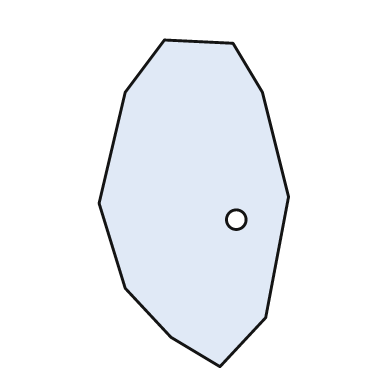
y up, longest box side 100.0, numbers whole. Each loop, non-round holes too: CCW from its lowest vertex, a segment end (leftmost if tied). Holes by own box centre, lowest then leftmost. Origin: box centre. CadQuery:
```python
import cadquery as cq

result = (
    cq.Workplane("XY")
    .moveTo(8.0, -50.0)
    .lineTo(22.0, -35.0)
    .lineTo(29.0, 2.0)
    .lineTo(21.0, 34.0)
    .lineTo(12.0, 49.0)
    .lineTo(-9.0, 50.0)
    .lineTo(-21.0, 34.0)
    .lineTo(-29.0, 0.0)
    .lineTo(-21.0, -26.0)
    .lineTo(-7.0, -41.0)
    .close()
    .moveTo(13.0, -5.0)
    .circle(3.0)
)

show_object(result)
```